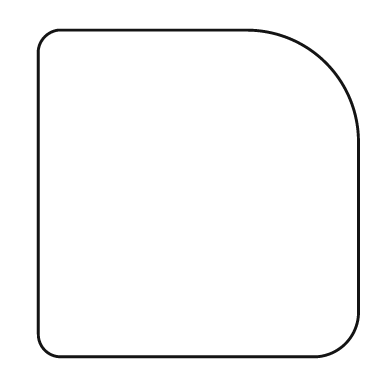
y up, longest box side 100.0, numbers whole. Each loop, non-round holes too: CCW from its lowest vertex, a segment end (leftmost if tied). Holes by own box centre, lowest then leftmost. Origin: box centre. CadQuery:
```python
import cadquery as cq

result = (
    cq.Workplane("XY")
    .moveTo(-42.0, -50.0)
    .lineTo(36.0, -50.0)
    .threePointArc((45.0, -46.0), (49.0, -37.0))
    .lineTo(49.0, 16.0)
    .threePointArc((39.0, 40.0), (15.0, 50.0))
    .lineTo(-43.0, 50.0)
    .threePointArc((-47.0, 48.0), (-49.0, 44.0))
    .lineTo(-49.0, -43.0)
    .threePointArc((-47.0, -48.0), (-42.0, -50.0))
    .close()
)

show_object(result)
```